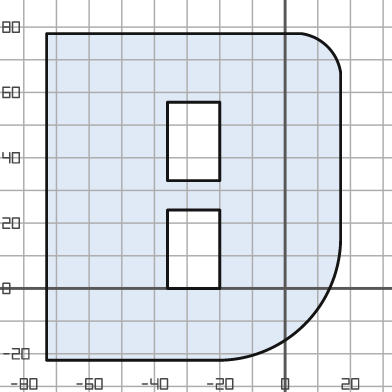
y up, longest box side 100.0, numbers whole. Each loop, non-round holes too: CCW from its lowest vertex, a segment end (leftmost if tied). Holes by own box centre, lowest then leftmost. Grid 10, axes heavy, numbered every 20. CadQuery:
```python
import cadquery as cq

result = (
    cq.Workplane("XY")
    .moveTo(-73.0, -22.0)
    .lineTo(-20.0, -22.0)
    .threePointArc((6.0, -11.0), (17.0, 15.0))
    .lineTo(17.0, 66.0)
    .threePointArc((13.0, 74.0), (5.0, 78.0))
    .lineTo(-73.0, 78.0)
    .close()
    .moveTo(-36.0, 0.0)
    .lineTo(-20.0, 0.0)
    .lineTo(-20.0, 24.0)
    .lineTo(-36.0, 24.0)
    .close()
    .moveTo(-36.0, 33.0)
    .lineTo(-20.0, 33.0)
    .lineTo(-20.0, 57.0)
    .lineTo(-36.0, 57.0)
    .close()
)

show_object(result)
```